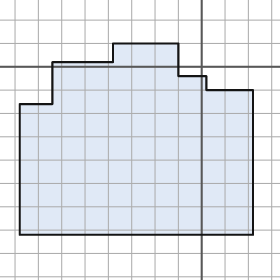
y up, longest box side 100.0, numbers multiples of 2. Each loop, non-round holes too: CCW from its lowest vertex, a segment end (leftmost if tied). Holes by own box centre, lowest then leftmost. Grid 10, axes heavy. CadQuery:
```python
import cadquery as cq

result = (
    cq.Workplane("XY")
    .moveTo(-78.0, -72.0)
    .lineTo(22.0, -72.0)
    .lineTo(22.0, -10.0)
    .lineTo(2.0, -10.0)
    .lineTo(2.0, -4.0)
    .lineTo(-10.0, -4.0)
    .lineTo(-10.0, 10.0)
    .lineTo(-38.0, 10.0)
    .lineTo(-38.0, 2.0)
    .lineTo(-64.0, 2.0)
    .lineTo(-64.0, -16.0)
    .lineTo(-78.0, -16.0)
    .close()
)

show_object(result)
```